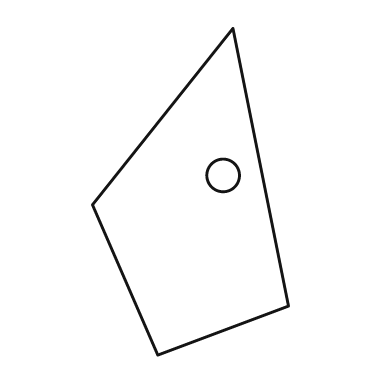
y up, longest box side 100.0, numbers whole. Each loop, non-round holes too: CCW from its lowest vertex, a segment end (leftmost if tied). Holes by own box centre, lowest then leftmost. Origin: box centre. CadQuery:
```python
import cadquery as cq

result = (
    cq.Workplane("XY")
    .moveTo(-10.0, -50.0)
    .lineTo(30.0, -35.0)
    .lineTo(13.0, 50.0)
    .lineTo(-30.0, -4.0)
    .close()
    .moveTo(10.0, 5.0)
    .circle(5.0)
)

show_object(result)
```